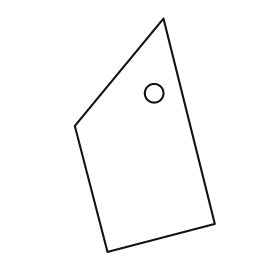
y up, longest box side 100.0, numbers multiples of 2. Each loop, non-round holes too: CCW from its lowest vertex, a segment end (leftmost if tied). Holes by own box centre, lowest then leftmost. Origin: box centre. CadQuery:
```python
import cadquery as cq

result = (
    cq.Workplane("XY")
    .moveTo(-16.0, -50.0)
    .lineTo(30.0, -38.0)
    .lineTo(8.0, 50.0)
    .lineTo(-30.0, 4.0)
    .close()
    .moveTo(4.0, 18.0)
    .circle(4.0)
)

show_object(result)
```